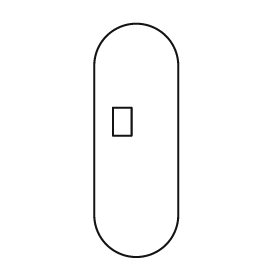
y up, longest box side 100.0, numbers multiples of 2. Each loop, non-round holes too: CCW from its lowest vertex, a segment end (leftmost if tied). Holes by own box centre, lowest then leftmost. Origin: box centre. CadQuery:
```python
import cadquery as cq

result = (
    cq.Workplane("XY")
    .moveTo(-18.0, -32.0)
    .threePointArc((0.0, -50.0), (18.0, -32.0))
    .lineTo(18.0, 32.0)
    .threePointArc((0.0, 50.0), (-18.0, 32.0))
    .close()
    .moveTo(-10.0, 2.0)
    .lineTo(-2.0, 2.0)
    .lineTo(-2.0, 14.0)
    .lineTo(-10.0, 14.0)
    .close()
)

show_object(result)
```